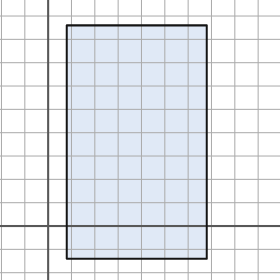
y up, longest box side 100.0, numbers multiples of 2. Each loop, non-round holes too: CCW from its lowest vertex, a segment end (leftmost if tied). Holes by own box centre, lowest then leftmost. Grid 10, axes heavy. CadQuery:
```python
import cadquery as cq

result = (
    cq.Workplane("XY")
    .moveTo(8.0, -14.0)
    .lineTo(68.0, -14.0)
    .lineTo(68.0, 86.0)
    .lineTo(8.0, 86.0)
    .close()
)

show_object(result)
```